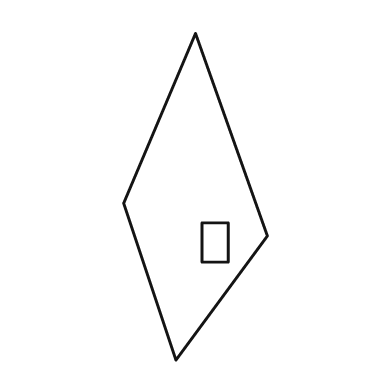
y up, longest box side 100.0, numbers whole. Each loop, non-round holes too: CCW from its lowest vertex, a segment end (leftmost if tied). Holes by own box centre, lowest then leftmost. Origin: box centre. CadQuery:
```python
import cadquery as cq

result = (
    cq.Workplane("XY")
    .moveTo(-6.0, -50.0)
    .lineTo(22.0, -12.0)
    .lineTo(0.0, 50.0)
    .lineTo(-22.0, -2.0)
    .close()
    .moveTo(2.0, -20.0)
    .lineTo(10.0, -20.0)
    .lineTo(10.0, -8.0)
    .lineTo(2.0, -8.0)
    .close()
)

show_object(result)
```